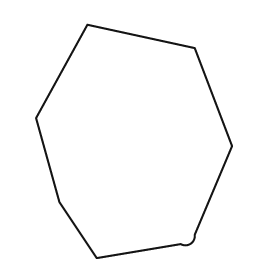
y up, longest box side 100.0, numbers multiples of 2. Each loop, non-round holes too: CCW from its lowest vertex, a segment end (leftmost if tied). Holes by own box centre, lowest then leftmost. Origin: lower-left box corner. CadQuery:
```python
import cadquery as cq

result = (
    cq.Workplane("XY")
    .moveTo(26.0, 0.0)
    .lineTo(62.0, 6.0)
    .threePointArc((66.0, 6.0), (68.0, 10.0))
    .lineTo(84.0, 48.0)
    .lineTo(68.0, 90.0)
    .lineTo(22.0, 100.0)
    .lineTo(0.0, 60.0)
    .lineTo(10.0, 24.0)
    .close()
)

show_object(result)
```